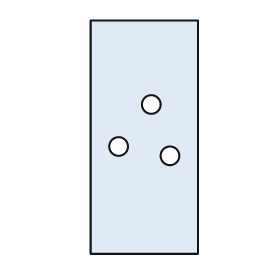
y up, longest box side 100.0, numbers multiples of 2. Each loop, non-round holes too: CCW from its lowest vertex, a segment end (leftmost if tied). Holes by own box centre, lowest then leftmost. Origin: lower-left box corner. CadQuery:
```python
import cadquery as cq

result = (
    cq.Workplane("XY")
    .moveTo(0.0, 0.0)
    .lineTo(46.0, 0.0)
    .lineTo(46.0, 100.0)
    .lineTo(0.0, 100.0)
    .close()
    .moveTo(34.0, 42.0)
    .circle(4.0)
    .moveTo(12.0, 46.0)
    .circle(4.0)
    .moveTo(26.0, 64.0)
    .circle(4.0)
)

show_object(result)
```